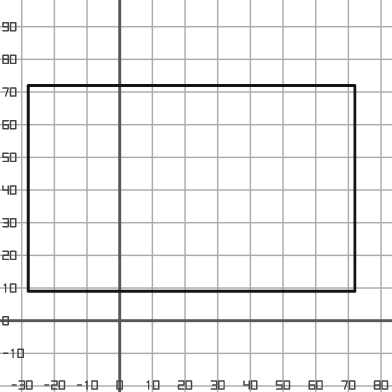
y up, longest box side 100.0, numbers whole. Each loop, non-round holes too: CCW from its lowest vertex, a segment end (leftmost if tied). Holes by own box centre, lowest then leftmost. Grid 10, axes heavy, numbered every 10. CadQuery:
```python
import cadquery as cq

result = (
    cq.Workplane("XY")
    .moveTo(-28.0, 9.0)
    .lineTo(72.0, 9.0)
    .lineTo(72.0, 72.0)
    .lineTo(-28.0, 72.0)
    .close()
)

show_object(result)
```